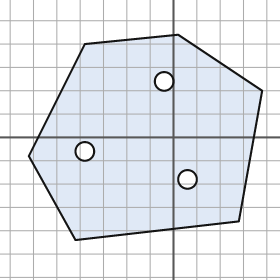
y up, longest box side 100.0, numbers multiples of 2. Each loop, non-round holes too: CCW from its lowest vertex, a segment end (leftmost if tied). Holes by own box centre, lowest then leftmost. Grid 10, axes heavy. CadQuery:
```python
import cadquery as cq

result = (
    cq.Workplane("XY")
    .moveTo(-42.0, -44.0)
    .lineTo(28.0, -36.0)
    .lineTo(38.0, 20.0)
    .lineTo(2.0, 44.0)
    .lineTo(-38.0, 40.0)
    .lineTo(-62.0, -8.0)
    .close()
    .moveTo(6.0, -18.0)
    .circle(4.0)
    .moveTo(-38.0, -6.0)
    .circle(4.0)
    .moveTo(-4.0, 24.0)
    .circle(4.0)
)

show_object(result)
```